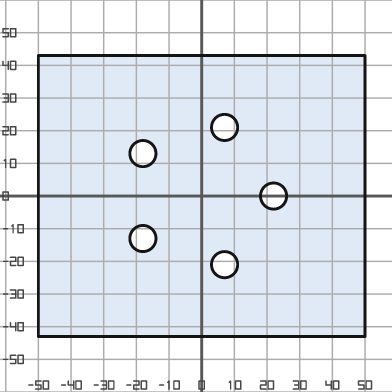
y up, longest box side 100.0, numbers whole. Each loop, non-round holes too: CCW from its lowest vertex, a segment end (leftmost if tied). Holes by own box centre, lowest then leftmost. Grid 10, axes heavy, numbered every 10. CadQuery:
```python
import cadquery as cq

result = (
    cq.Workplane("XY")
    .moveTo(-50.0, -43.0)
    .lineTo(50.0, -43.0)
    .lineTo(50.0, 43.0)
    .lineTo(-50.0, 43.0)
    .close()
    .moveTo(7.0, -21.0)
    .circle(4.0)
    .moveTo(-18.0, -13.0)
    .circle(4.0)
    .moveTo(22.0, 0.0)
    .circle(4.0)
    .moveTo(-18.0, 13.0)
    .circle(4.0)
    .moveTo(7.0, 21.0)
    .circle(4.0)
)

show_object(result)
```